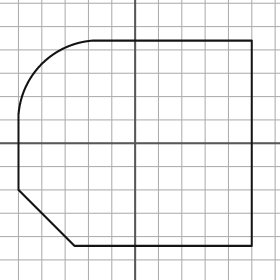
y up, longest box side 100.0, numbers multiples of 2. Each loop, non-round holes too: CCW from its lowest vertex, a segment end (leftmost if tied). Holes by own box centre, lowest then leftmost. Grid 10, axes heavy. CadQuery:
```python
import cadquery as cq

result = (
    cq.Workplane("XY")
    .moveTo(-26.0, -44.0)
    .lineTo(50.0, -44.0)
    .lineTo(50.0, 44.0)
    .lineTo(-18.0, 44.0)
    .threePointArc((-40.0, 34.0), (-50.0, 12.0))
    .lineTo(-50.0, -20.0)
    .close()
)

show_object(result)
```